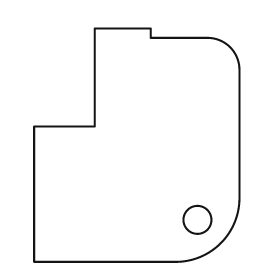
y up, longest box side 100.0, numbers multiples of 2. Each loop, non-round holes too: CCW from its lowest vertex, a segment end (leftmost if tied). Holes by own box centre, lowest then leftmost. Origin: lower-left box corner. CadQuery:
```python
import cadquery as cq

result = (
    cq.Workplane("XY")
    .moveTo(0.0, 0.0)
    .lineTo(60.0, 0.0)
    .threePointArc((80.0, 8.0), (88.0, 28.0))
    .lineTo(88.0, 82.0)
    .threePointArc((84.0, 92.0), (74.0, 96.0))
    .lineTo(50.0, 96.0)
    .lineTo(50.0, 100.0)
    .lineTo(26.0, 100.0)
    .lineTo(26.0, 58.0)
    .lineTo(0.0, 58.0)
    .close()
    .moveTo(70.0, 18.0)
    .circle(6.0)
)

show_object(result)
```